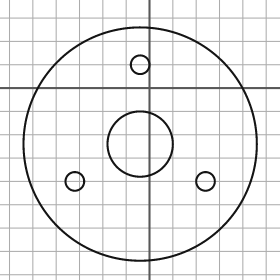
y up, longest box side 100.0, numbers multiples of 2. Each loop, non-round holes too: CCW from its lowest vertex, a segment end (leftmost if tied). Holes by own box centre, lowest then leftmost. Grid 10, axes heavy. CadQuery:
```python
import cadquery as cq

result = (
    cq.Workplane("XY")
    .moveTo(-4.0, -24.0)
    .circle(50.0)
    .moveTo(-32.0, -40.0)
    .circle(4.0)
    .moveTo(24.0, -40.0)
    .circle(4.0)
    .moveTo(-4.0, -24.0)
    .circle(14.0)
    .moveTo(-4.0, 10.0)
    .circle(4.0)
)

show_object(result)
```